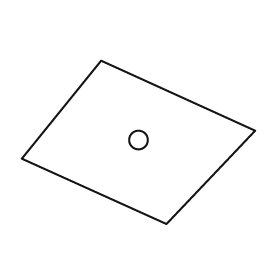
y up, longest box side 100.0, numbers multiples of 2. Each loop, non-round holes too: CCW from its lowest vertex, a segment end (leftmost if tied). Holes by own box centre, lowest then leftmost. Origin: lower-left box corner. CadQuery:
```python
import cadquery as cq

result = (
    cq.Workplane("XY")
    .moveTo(62.0, 0.0)
    .lineTo(100.0, 40.0)
    .lineTo(34.0, 70.0)
    .lineTo(0.0, 28.0)
    .close()
    .moveTo(50.0, 36.0)
    .circle(4.0)
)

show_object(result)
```